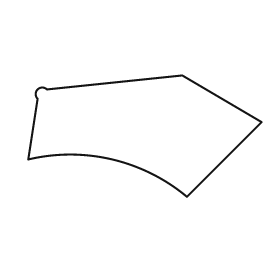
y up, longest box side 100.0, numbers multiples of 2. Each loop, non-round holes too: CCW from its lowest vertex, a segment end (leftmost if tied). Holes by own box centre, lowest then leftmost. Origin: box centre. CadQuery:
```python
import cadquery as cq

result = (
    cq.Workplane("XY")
    .moveTo(18.0, -26.0)
    .lineTo(50.0, 6.0)
    .lineTo(16.0, 26.0)
    .lineTo(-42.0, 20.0)
    .threePointArc((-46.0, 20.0), (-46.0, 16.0))
    .lineTo(-50.0, -10.0)
    .threePointArc((-14.0, -10.0), (18.0, -26.0))
    .close()
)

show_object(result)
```